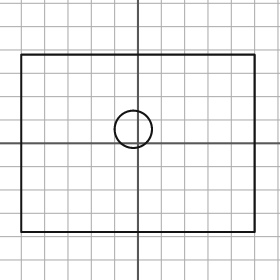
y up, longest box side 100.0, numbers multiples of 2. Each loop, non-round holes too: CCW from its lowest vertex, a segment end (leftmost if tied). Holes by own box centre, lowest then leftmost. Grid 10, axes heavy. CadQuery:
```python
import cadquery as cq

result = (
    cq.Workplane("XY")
    .moveTo(-50.0, -38.0)
    .lineTo(50.0, -38.0)
    .lineTo(50.0, 38.0)
    .lineTo(-50.0, 38.0)
    .close()
    .moveTo(-2.0, 6.0)
    .circle(8.0)
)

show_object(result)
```